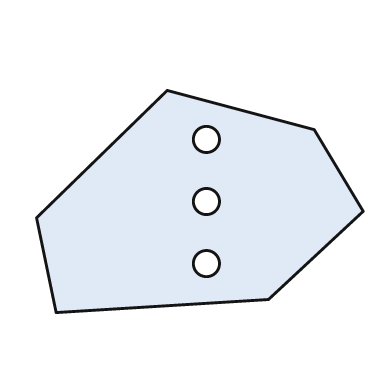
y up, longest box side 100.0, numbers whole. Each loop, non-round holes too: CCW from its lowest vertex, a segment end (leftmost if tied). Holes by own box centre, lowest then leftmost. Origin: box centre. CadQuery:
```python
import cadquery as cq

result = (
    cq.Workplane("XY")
    .moveTo(-44.0, -34.0)
    .lineTo(21.0, -30.0)
    .lineTo(50.0, -3.0)
    .lineTo(35.0, 22.0)
    .lineTo(-10.0, 34.0)
    .lineTo(-50.0, -5.0)
    .close()
    .moveTo(2.0, -19.0)
    .circle(4.0)
    .moveTo(2.0, 0.0)
    .circle(4.0)
    .moveTo(2.0, 19.0)
    .circle(4.0)
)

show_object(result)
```